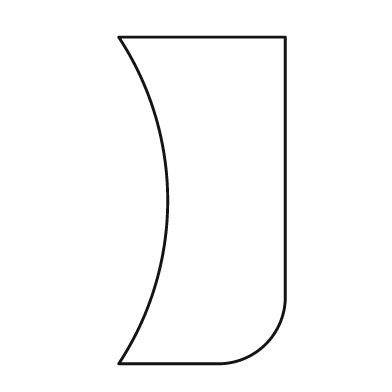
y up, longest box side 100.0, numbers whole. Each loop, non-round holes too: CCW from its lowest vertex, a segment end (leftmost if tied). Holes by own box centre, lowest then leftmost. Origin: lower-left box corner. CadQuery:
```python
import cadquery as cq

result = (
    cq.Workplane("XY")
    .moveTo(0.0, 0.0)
    .lineTo(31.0, 0.0)
    .threePointArc((45.0, 6.0), (51.0, 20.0))
    .lineTo(51.0, 100.0)
    .lineTo(0.0, 100.0)
    .threePointArc((15.0, 50.0), (0.0, 0.0))
    .close()
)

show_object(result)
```